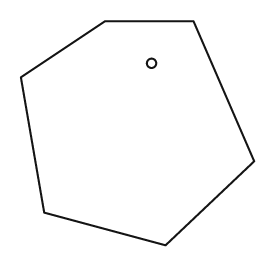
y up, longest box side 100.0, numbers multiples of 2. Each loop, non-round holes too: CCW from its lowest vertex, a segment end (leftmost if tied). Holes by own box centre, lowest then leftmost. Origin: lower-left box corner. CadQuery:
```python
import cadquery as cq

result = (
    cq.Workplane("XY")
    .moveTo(62.0, 0.0)
    .lineTo(100.0, 36.0)
    .lineTo(74.0, 96.0)
    .lineTo(36.0, 96.0)
    .lineTo(0.0, 72.0)
    .lineTo(10.0, 14.0)
    .close()
    .moveTo(56.0, 78.0)
    .circle(2.0)
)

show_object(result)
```